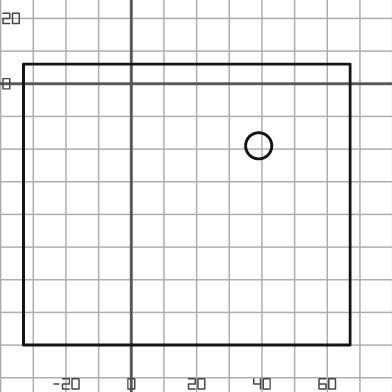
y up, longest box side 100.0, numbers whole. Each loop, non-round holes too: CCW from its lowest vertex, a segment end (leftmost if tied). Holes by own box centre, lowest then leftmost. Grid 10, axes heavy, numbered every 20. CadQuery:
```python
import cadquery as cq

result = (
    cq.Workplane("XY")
    .moveTo(-33.0, -80.0)
    .lineTo(67.0, -80.0)
    .lineTo(67.0, 6.0)
    .lineTo(-33.0, 6.0)
    .close()
    .moveTo(39.0, -19.0)
    .circle(4.0)
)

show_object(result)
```